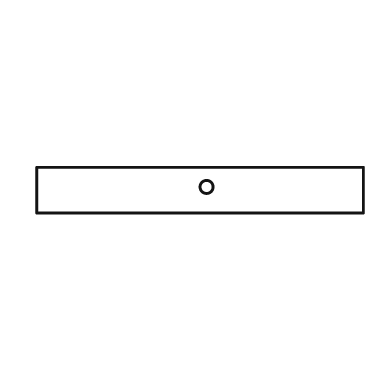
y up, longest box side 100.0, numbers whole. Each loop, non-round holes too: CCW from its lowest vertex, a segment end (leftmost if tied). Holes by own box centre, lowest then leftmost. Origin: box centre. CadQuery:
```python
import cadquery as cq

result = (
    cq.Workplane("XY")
    .moveTo(-50.0, -7.0)
    .lineTo(50.0, -7.0)
    .lineTo(50.0, 7.0)
    .lineTo(-50.0, 7.0)
    .close()
    .moveTo(2.0, 1.0)
    .circle(2.0)
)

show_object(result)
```